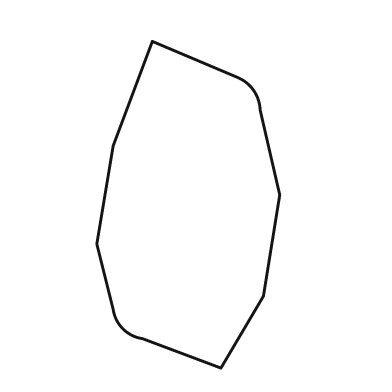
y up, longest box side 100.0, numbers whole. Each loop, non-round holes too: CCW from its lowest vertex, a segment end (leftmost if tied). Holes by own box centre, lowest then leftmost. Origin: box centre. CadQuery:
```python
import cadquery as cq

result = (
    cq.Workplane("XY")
    .moveTo(10.0, -50.0)
    .lineTo(23.0, -28.0)
    .lineTo(28.0, 3.0)
    .lineTo(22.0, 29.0)
    .threePointArc((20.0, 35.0), (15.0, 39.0))
    .lineTo(-11.0, 50.0)
    .lineTo(-23.0, 18.0)
    .lineTo(-28.0, -12.0)
    .lineTo(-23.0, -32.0)
    .threePointArc((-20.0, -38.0), (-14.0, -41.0))
    .close()
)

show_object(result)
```